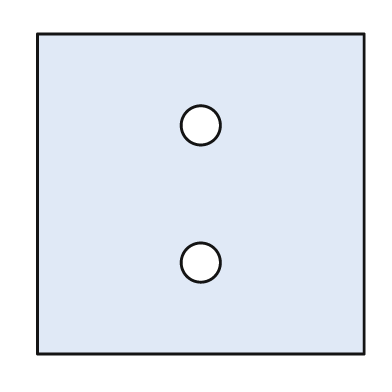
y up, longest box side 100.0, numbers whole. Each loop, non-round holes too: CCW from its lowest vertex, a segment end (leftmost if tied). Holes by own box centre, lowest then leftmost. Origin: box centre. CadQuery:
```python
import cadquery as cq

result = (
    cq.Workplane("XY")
    .moveTo(-50.0, -49.0)
    .lineTo(50.0, -49.0)
    .lineTo(50.0, 49.0)
    .lineTo(-50.0, 49.0)
    .close()
    .moveTo(0.0, -21.0)
    .circle(6.0)
    .moveTo(0.0, 21.0)
    .circle(6.0)
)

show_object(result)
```